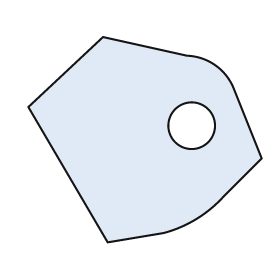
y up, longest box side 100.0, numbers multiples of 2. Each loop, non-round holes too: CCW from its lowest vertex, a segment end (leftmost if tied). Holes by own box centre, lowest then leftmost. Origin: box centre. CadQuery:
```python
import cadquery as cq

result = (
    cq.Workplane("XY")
    .moveTo(-16.0, -44.0)
    .lineTo(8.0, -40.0)
    .threePointArc((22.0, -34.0), (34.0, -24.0))
    .lineTo(50.0, -8.0)
    .lineTo(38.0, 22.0)
    .threePointArc((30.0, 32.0), (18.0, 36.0))
    .lineTo(-18.0, 44.0)
    .lineTo(-50.0, 14.0)
    .close()
    .moveTo(20.0, 6.0)
    .circle(10.0)
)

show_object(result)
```